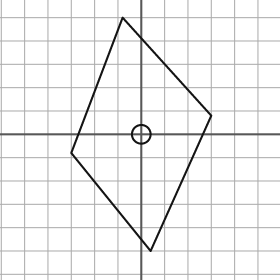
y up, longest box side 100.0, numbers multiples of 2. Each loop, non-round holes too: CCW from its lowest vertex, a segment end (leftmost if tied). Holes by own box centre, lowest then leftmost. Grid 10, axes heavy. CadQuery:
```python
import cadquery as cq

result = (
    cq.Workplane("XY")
    .moveTo(4.0, -50.0)
    .lineTo(30.0, 8.0)
    .lineTo(-8.0, 50.0)
    .lineTo(-30.0, -8.0)
    .close()
    .moveTo(0.0, 0.0)
    .circle(4.0)
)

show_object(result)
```